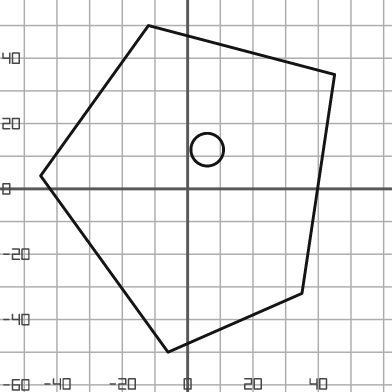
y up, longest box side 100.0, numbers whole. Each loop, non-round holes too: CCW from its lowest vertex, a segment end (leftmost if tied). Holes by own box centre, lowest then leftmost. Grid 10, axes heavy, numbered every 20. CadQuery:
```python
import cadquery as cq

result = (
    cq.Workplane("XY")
    .moveTo(-6.0, -50.0)
    .lineTo(35.0, -32.0)
    .lineTo(45.0, 35.0)
    .lineTo(-12.0, 50.0)
    .lineTo(-45.0, 4.0)
    .close()
    .moveTo(6.0, 12.0)
    .circle(5.0)
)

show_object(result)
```